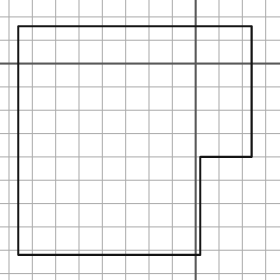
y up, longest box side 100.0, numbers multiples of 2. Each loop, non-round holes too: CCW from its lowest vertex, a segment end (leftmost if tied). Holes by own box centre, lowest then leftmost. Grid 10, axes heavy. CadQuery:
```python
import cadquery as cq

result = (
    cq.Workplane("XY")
    .moveTo(-76.0, -82.0)
    .lineTo(2.0, -82.0)
    .lineTo(2.0, -40.0)
    .lineTo(24.0, -40.0)
    .lineTo(24.0, 16.0)
    .lineTo(-76.0, 16.0)
    .close()
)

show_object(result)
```